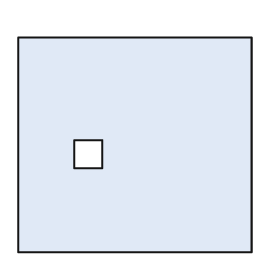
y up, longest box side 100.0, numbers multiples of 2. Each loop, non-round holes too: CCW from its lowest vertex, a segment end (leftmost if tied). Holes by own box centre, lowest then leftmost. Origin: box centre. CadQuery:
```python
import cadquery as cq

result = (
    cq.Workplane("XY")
    .moveTo(-50.0, -46.0)
    .lineTo(50.0, -46.0)
    .lineTo(50.0, 46.0)
    .lineTo(-50.0, 46.0)
    .close()
    .moveTo(-26.0, -10.0)
    .lineTo(-14.0, -10.0)
    .lineTo(-14.0, 2.0)
    .lineTo(-26.0, 2.0)
    .close()
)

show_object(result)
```